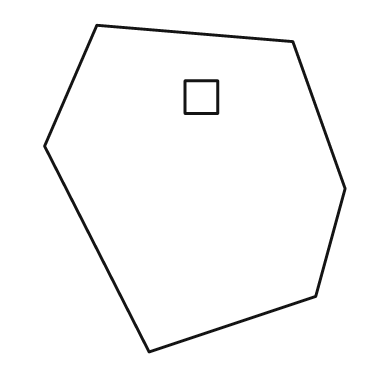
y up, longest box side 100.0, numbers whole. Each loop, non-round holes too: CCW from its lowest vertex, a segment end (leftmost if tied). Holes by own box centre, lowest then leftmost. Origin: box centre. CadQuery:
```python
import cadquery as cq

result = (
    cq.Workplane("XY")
    .moveTo(-14.0, -50.0)
    .lineTo(37.0, -33.0)
    .lineTo(46.0, 0.0)
    .lineTo(30.0, 45.0)
    .lineTo(-30.0, 50.0)
    .lineTo(-46.0, 13.0)
    .close()
    .moveTo(-3.0, 23.0)
    .lineTo(7.0, 23.0)
    .lineTo(7.0, 33.0)
    .lineTo(-3.0, 33.0)
    .close()
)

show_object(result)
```